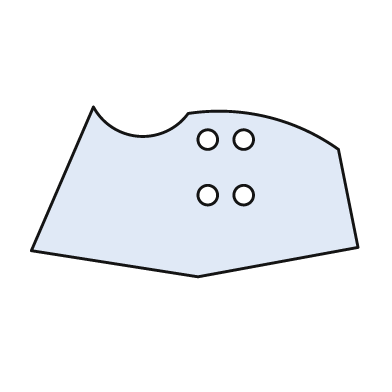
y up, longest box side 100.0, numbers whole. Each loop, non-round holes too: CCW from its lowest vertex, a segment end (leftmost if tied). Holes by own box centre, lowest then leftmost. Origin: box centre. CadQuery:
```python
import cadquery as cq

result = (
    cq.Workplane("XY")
    .moveTo(1.0, -26.0)
    .lineTo(50.0, -17.0)
    .lineTo(44.0, 13.0)
    .threePointArc((22.0, 23.0), (-2.0, 24.0))
    .threePointArc((-17.0, 17.0), (-31.0, 26.0))
    .lineTo(-50.0, -18.0)
    .close()
    .moveTo(4.0, -1.0)
    .circle(3.0)
    .moveTo(15.0, -1.0)
    .circle(3.0)
    .moveTo(4.0, 16.0)
    .circle(3.0)
    .moveTo(15.0, 16.0)
    .circle(3.0)
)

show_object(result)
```